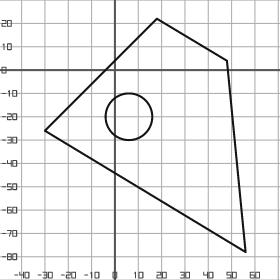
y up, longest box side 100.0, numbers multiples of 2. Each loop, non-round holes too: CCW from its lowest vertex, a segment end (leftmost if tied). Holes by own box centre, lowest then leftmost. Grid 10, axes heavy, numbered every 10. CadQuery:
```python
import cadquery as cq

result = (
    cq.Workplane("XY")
    .moveTo(56.0, -78.0)
    .lineTo(48.0, 4.0)
    .lineTo(18.0, 22.0)
    .lineTo(-30.0, -26.0)
    .close()
    .moveTo(6.0, -20.0)
    .circle(10.0)
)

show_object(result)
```